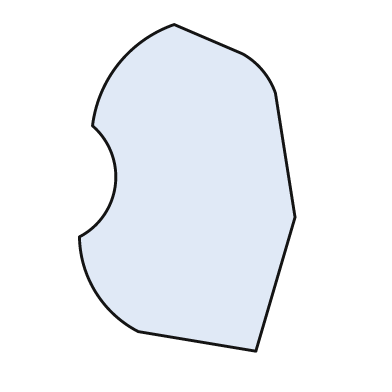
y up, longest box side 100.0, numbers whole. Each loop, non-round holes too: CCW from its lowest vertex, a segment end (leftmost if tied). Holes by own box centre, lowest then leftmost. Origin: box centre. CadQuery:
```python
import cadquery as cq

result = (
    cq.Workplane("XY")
    .moveTo(21.0, -50.0)
    .lineTo(33.0, -9.0)
    .lineTo(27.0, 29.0)
    .threePointArc((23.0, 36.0), (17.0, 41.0))
    .lineTo(-4.0, 50.0)
    .threePointArc((-21.0, 38.0), (-29.0, 19.0))
    .threePointArc((-22.0, 1.0), (-33.0, -15.0))
    .threePointArc((-28.0, -32.0), (-15.0, -44.0))
    .close()
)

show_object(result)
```